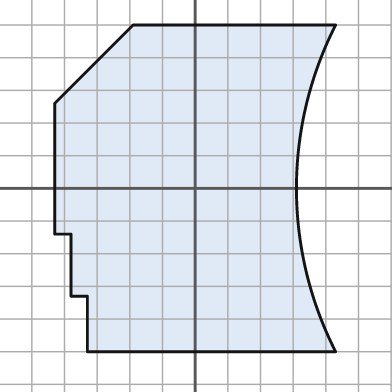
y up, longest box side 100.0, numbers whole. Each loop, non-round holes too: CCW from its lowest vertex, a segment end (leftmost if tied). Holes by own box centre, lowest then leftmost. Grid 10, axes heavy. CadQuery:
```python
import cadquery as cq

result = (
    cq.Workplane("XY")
    .moveTo(-33.0, -50.0)
    .lineTo(43.0, -50.0)
    .threePointArc((31.0, 0.0), (43.0, 50.0))
    .lineTo(-19.0, 50.0)
    .lineTo(-43.0, 26.0)
    .lineTo(-43.0, -14.0)
    .lineTo(-38.0, -14.0)
    .lineTo(-38.0, -33.0)
    .lineTo(-33.0, -33.0)
    .close()
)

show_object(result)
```